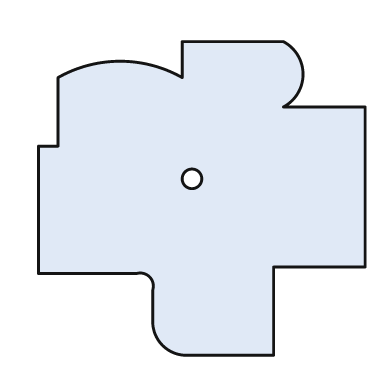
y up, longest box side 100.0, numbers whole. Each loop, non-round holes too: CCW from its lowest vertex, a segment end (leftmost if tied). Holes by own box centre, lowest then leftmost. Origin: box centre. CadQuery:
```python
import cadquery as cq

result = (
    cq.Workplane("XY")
    .moveTo(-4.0, -48.0)
    .lineTo(22.0, -48.0)
    .lineTo(22.0, -21.0)
    .lineTo(50.0, -21.0)
    .lineTo(50.0, 28.0)
    .lineTo(25.0, 28.0)
    .threePointArc((31.0, 38.0), (25.0, 48.0))
    .lineTo(-6.0, 48.0)
    .lineTo(-6.0, 37.0)
    .threePointArc((-25.0, 42.0), (-44.0, 37.0))
    .lineTo(-44.0, 16.0)
    .lineTo(-50.0, 16.0)
    .lineTo(-50.0, -23.0)
    .lineTo(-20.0, -23.0)
    .threePointArc((-16.0, -24.0), (-15.0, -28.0))
    .lineTo(-15.0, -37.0)
    .threePointArc((-12.0, -45.0), (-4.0, -48.0))
    .close()
    .moveTo(-3.0, 6.0)
    .circle(3.0)
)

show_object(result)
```